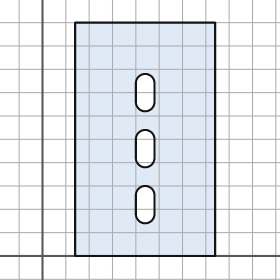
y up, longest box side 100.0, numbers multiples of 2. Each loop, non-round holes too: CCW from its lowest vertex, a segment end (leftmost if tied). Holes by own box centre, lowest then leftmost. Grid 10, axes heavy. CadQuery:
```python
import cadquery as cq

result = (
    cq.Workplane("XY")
    .moveTo(14.0, 0.0)
    .lineTo(74.0, 0.0)
    .lineTo(74.0, 100.0)
    .lineTo(14.0, 100.0)
    .close()
    .moveTo(40.0, 18.0)
    .threePointArc((44.0, 14.0), (48.0, 18.0))
    .lineTo(48.0, 26.0)
    .threePointArc((44.0, 30.0), (40.0, 26.0))
    .close()
    .moveTo(40.0, 42.0)
    .threePointArc((44.0, 38.0), (48.0, 42.0))
    .lineTo(48.0, 50.0)
    .threePointArc((44.0, 54.0), (40.0, 50.0))
    .close()
    .moveTo(40.0, 66.0)
    .threePointArc((44.0, 62.0), (48.0, 66.0))
    .lineTo(48.0, 74.0)
    .threePointArc((44.0, 78.0), (40.0, 74.0))
    .close()
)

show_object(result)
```